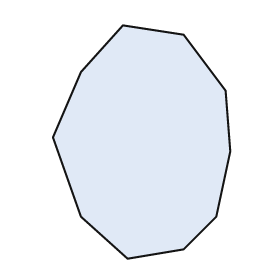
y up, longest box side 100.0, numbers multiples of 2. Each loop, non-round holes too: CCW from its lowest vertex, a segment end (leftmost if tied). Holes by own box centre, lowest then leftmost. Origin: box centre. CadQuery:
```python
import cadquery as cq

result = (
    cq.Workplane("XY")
    .moveTo(-6.0, -50.0)
    .lineTo(18.0, -46.0)
    .lineTo(32.0, -32.0)
    .lineTo(38.0, -4.0)
    .lineTo(36.0, 22.0)
    .lineTo(18.0, 46.0)
    .lineTo(-8.0, 50.0)
    .lineTo(-26.0, 30.0)
    .lineTo(-38.0, 2.0)
    .lineTo(-26.0, -32.0)
    .close()
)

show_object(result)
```